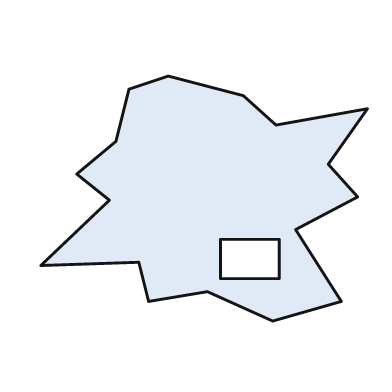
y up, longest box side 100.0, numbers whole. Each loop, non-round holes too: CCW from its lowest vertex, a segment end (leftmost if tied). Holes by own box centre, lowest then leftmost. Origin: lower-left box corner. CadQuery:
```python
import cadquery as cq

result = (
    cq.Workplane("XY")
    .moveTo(71.0, 0.0)
    .lineTo(92.0, 6.0)
    .lineTo(78.0, 28.0)
    .lineTo(97.0, 38.0)
    .lineTo(88.0, 48.0)
    .lineTo(100.0, 65.0)
    .lineTo(72.0, 60.0)
    .lineTo(62.0, 69.0)
    .lineTo(39.0, 75.0)
    .lineTo(27.0, 71.0)
    .lineTo(23.0, 55.0)
    .lineTo(11.0, 45.0)
    .lineTo(21.0, 37.0)
    .lineTo(0.0, 17.0)
    .lineTo(30.0, 18.0)
    .lineTo(33.0, 6.0)
    .lineTo(51.0, 9.0)
    .close()
    .moveTo(55.0, 13.0)
    .lineTo(73.0, 13.0)
    .lineTo(73.0, 25.0)
    .lineTo(55.0, 25.0)
    .close()
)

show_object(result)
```